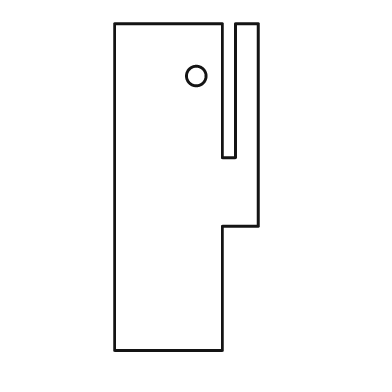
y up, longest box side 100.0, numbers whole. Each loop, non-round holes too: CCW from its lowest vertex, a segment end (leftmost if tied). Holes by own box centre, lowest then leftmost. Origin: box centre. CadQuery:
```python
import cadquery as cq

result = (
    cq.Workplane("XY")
    .moveTo(-22.0, -50.0)
    .lineTo(11.0, -50.0)
    .lineTo(11.0, -12.0)
    .lineTo(22.0, -12.0)
    .lineTo(22.0, 50.0)
    .lineTo(15.0, 50.0)
    .lineTo(15.0, 9.0)
    .lineTo(11.0, 9.0)
    .lineTo(11.0, 50.0)
    .lineTo(-22.0, 50.0)
    .close()
    .moveTo(3.0, 34.0)
    .circle(3.0)
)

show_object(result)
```